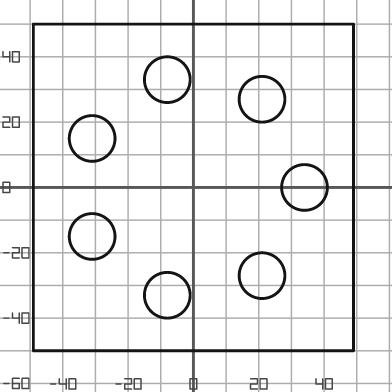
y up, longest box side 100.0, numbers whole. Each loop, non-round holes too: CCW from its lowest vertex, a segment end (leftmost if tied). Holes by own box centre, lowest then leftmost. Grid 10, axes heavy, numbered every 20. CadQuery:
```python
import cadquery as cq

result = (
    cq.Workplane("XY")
    .moveTo(-49.0, -50.0)
    .lineTo(49.0, -50.0)
    .lineTo(49.0, 50.0)
    .lineTo(-49.0, 50.0)
    .close()
    .moveTo(-8.0, -33.0)
    .circle(7.0)
    .moveTo(21.0, -27.0)
    .circle(7.0)
    .moveTo(-31.0, -15.0)
    .circle(7.0)
    .moveTo(34.0, 0.0)
    .circle(7.0)
    .moveTo(-31.0, 15.0)
    .circle(7.0)
    .moveTo(21.0, 27.0)
    .circle(7.0)
    .moveTo(-8.0, 33.0)
    .circle(7.0)
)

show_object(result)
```